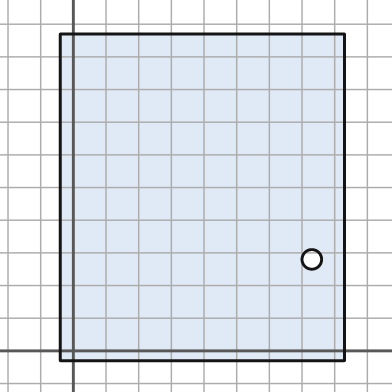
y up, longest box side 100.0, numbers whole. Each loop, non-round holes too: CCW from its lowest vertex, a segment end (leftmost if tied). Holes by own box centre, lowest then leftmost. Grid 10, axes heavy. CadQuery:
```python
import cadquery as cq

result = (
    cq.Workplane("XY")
    .moveTo(-4.0, -3.0)
    .lineTo(83.0, -3.0)
    .lineTo(83.0, 97.0)
    .lineTo(-4.0, 97.0)
    .close()
    .moveTo(73.0, 28.0)
    .circle(3.0)
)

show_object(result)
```